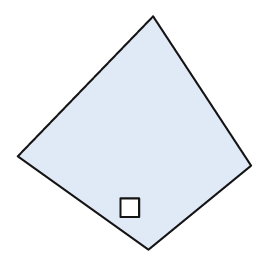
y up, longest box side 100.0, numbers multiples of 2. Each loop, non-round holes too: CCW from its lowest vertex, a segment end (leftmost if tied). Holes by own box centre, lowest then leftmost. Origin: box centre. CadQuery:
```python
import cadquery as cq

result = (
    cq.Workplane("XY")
    .moveTo(6.0, -50.0)
    .lineTo(50.0, -14.0)
    .lineTo(8.0, 50.0)
    .lineTo(-50.0, -10.0)
    .close()
    .moveTo(-6.0, -36.0)
    .lineTo(2.0, -36.0)
    .lineTo(2.0, -28.0)
    .lineTo(-6.0, -28.0)
    .close()
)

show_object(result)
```